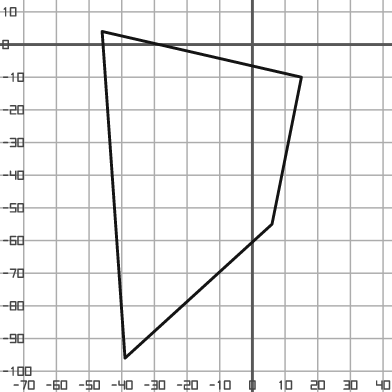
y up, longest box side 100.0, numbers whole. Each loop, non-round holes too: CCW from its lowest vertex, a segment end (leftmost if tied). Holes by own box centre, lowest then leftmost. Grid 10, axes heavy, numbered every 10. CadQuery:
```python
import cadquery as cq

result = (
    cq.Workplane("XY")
    .moveTo(-39.0, -96.0)
    .lineTo(6.0, -55.0)
    .lineTo(15.0, -10.0)
    .lineTo(-46.0, 4.0)
    .close()
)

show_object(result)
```